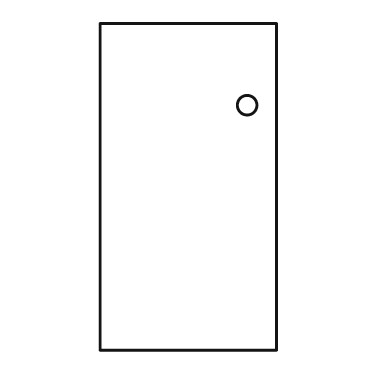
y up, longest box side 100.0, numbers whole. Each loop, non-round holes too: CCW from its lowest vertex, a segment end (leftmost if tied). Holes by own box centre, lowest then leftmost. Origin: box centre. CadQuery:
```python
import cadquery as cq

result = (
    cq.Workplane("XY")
    .moveTo(-27.0, -50.0)
    .lineTo(27.0, -50.0)
    .lineTo(27.0, 50.0)
    .lineTo(-27.0, 50.0)
    .close()
    .moveTo(18.0, 25.0)
    .circle(3.0)
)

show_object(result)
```